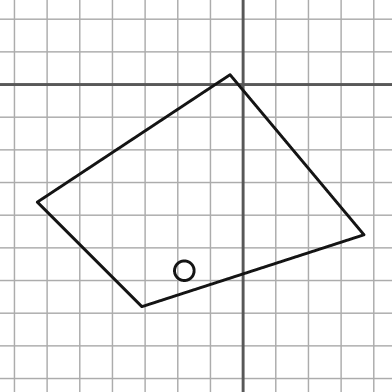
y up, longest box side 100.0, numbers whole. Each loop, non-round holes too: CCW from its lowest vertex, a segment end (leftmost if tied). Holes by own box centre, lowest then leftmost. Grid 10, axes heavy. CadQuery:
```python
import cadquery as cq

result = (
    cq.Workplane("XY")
    .moveTo(-31.0, -68.0)
    .lineTo(37.0, -46.0)
    .lineTo(-4.0, 3.0)
    .lineTo(-63.0, -36.0)
    .close()
    .moveTo(-18.0, -57.0)
    .circle(3.0)
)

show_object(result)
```